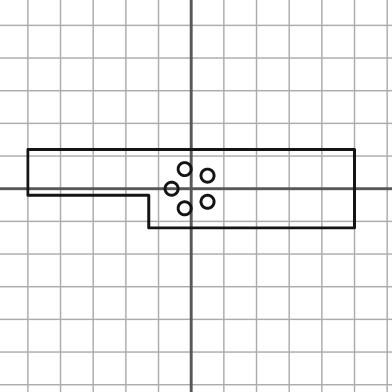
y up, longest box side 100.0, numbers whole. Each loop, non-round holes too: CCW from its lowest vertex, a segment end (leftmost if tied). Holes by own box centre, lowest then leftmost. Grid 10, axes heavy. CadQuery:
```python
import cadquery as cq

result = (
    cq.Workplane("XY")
    .moveTo(-13.0, -12.0)
    .lineTo(50.0, -12.0)
    .lineTo(50.0, 12.0)
    .lineTo(-50.0, 12.0)
    .lineTo(-50.0, -2.0)
    .lineTo(-13.0, -2.0)
    .close()
    .moveTo(-2.0, -6.0)
    .circle(2.0)
    .moveTo(5.0, -4.0)
    .circle(2.0)
    .moveTo(-6.0, 0.0)
    .circle(2.0)
    .moveTo(5.0, 4.0)
    .circle(2.0)
    .moveTo(-2.0, 6.0)
    .circle(2.0)
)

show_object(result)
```